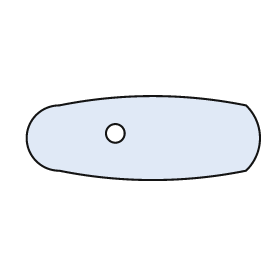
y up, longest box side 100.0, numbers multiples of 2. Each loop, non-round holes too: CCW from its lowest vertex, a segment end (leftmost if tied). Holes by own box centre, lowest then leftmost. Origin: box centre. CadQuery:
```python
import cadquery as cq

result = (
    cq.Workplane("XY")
    .moveTo(-36.0, -14.0)
    .threePointArc((4.0, -18.0), (44.0, -14.0))
    .threePointArc((50.0, 0.0), (44.0, 14.0))
    .threePointArc((4.0, 18.0), (-36.0, 14.0))
    .threePointArc((-50.0, 0.0), (-36.0, -14.0))
    .close()
    .moveTo(-12.0, 2.0)
    .circle(4.0)
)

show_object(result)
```